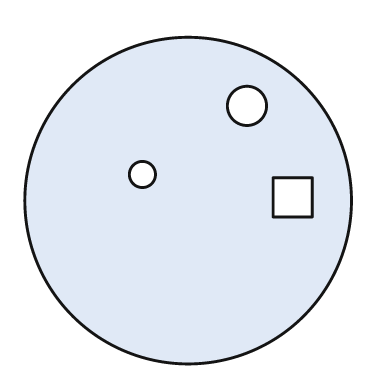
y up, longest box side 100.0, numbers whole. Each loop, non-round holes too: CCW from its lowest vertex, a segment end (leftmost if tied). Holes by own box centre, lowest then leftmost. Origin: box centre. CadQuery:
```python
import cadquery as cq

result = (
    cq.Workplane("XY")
    .moveTo(0.0, 0.0)
    .circle(50.0)
    .moveTo(26.0, -5.0)
    .lineTo(38.0, -5.0)
    .lineTo(38.0, 7.0)
    .lineTo(26.0, 7.0)
    .close()
    .moveTo(-14.0, 8.0)
    .circle(4.0)
    .moveTo(18.0, 29.0)
    .circle(6.0)
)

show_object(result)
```